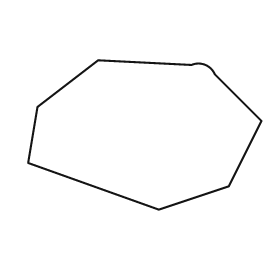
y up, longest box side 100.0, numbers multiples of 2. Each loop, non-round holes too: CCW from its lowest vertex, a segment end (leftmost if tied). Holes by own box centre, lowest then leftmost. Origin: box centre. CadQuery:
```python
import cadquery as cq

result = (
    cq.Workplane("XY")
    .moveTo(6.0, -32.0)
    .lineTo(36.0, -22.0)
    .lineTo(50.0, 6.0)
    .lineTo(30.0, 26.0)
    .threePointArc((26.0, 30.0), (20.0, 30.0))
    .lineTo(-20.0, 32.0)
    .lineTo(-46.0, 12.0)
    .lineTo(-50.0, -12.0)
    .close()
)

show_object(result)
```